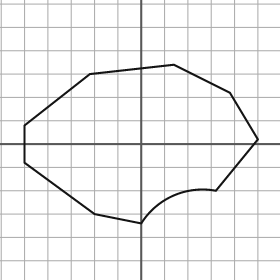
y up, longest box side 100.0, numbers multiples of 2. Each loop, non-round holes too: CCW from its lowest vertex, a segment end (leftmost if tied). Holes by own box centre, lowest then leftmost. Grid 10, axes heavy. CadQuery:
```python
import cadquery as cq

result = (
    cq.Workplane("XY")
    .moveTo(0.0, -34.0)
    .threePointArc((14.0, -22.0), (32.0, -20.0))
    .lineTo(50.0, 2.0)
    .lineTo(38.0, 22.0)
    .lineTo(14.0, 34.0)
    .lineTo(-22.0, 30.0)
    .lineTo(-50.0, 8.0)
    .lineTo(-50.0, -8.0)
    .lineTo(-20.0, -30.0)
    .close()
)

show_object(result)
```